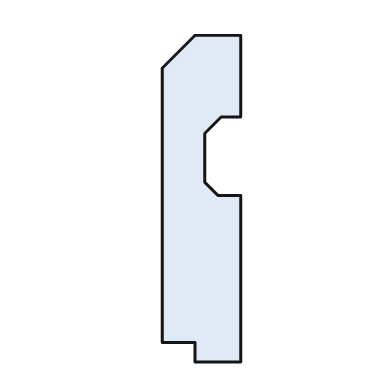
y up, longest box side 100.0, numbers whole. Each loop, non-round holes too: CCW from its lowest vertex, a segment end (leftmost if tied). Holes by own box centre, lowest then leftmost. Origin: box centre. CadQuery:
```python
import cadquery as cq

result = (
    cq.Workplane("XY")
    .moveTo(-2.0, -50.0)
    .lineTo(12.0, -50.0)
    .lineTo(12.0, 1.0)
    .lineTo(5.0, 1.0)
    .lineTo(1.0, 5.0)
    .lineTo(1.0, 20.0)
    .lineTo(6.0, 25.0)
    .lineTo(12.0, 25.0)
    .lineTo(12.0, 50.0)
    .lineTo(-2.0, 50.0)
    .lineTo(-12.0, 40.0)
    .lineTo(-12.0, -44.0)
    .lineTo(-2.0, -44.0)
    .close()
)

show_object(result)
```